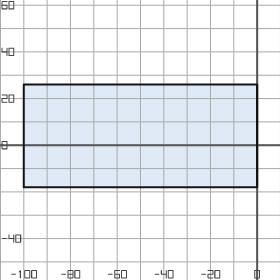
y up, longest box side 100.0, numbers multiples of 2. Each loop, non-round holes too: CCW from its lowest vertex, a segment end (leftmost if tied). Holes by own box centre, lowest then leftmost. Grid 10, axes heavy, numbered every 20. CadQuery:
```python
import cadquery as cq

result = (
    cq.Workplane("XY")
    .moveTo(-100.0, -18.0)
    .lineTo(0.0, -18.0)
    .lineTo(0.0, 26.0)
    .lineTo(-100.0, 26.0)
    .close()
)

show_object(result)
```